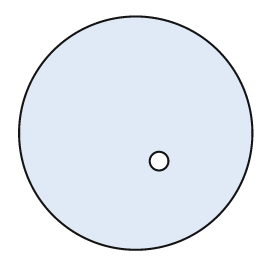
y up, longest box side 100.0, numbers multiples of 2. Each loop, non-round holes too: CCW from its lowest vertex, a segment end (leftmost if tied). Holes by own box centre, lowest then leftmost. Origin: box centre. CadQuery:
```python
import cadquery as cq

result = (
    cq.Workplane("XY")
    .moveTo(0.0, 0.0)
    .circle(50.0)
    .moveTo(10.0, -12.0)
    .circle(4.0)
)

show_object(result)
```